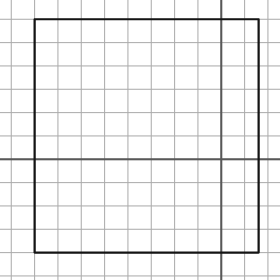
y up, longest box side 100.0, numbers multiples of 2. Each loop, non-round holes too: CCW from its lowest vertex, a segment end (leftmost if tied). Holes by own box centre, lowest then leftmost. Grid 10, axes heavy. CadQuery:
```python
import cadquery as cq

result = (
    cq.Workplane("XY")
    .moveTo(-80.0, -40.0)
    .lineTo(16.0, -40.0)
    .lineTo(16.0, 60.0)
    .lineTo(-80.0, 60.0)
    .close()
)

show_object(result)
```